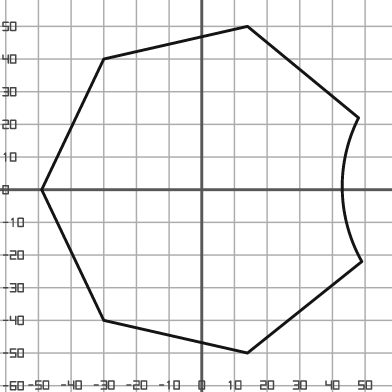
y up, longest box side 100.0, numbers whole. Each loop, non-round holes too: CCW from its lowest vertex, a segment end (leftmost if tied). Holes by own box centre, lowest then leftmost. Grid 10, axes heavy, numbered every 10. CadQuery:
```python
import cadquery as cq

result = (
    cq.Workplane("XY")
    .moveTo(14.0, -50.0)
    .lineTo(49.0, -22.0)
    .threePointArc((43.0, 0.0), (48.0, 22.0))
    .lineTo(14.0, 50.0)
    .lineTo(-30.0, 40.0)
    .lineTo(-49.0, 0.0)
    .lineTo(-30.0, -40.0)
    .close()
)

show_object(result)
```